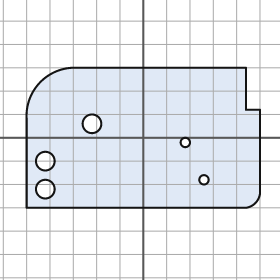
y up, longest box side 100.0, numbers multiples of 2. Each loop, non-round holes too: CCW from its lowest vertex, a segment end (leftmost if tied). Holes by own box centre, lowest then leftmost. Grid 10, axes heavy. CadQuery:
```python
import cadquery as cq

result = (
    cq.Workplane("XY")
    .moveTo(-50.0, -30.0)
    .lineTo(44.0, -30.0)
    .threePointArc((48.0, -28.0), (50.0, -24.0))
    .lineTo(50.0, 12.0)
    .lineTo(44.0, 12.0)
    .lineTo(44.0, 30.0)
    .lineTo(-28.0, 30.0)
    .threePointArc((-44.0, 24.0), (-50.0, 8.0))
    .close()
    .moveTo(-42.0, -22.0)
    .circle(4.0)
    .moveTo(26.0, -18.0)
    .circle(2.0)
    .moveTo(-42.0, -10.0)
    .circle(4.0)
    .moveTo(18.0, -2.0)
    .circle(2.0)
    .moveTo(-22.0, 6.0)
    .circle(4.0)
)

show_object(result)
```